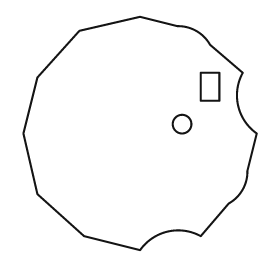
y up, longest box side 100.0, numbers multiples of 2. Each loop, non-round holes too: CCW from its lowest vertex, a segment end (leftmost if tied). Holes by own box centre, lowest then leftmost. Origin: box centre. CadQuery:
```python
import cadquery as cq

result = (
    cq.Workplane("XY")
    .moveTo(0.0, -50.0)
    .threePointArc((12.0, -42.0), (26.0, -44.0))
    .lineTo(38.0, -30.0)
    .threePointArc((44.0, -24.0), (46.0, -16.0))
    .lineTo(50.0, 0.0)
    .threePointArc((42.0, 12.0), (44.0, 26.0))
    .lineTo(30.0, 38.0)
    .threePointArc((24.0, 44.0), (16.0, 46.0))
    .lineTo(0.0, 50.0)
    .lineTo(-26.0, 44.0)
    .lineTo(-44.0, 24.0)
    .lineTo(-50.0, 0.0)
    .lineTo(-44.0, -26.0)
    .lineTo(-24.0, -44.0)
    .close()
    .moveTo(18.0, 4.0)
    .circle(4.0)
    .moveTo(26.0, 14.0)
    .lineTo(34.0, 14.0)
    .lineTo(34.0, 26.0)
    .lineTo(26.0, 26.0)
    .close()
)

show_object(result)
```